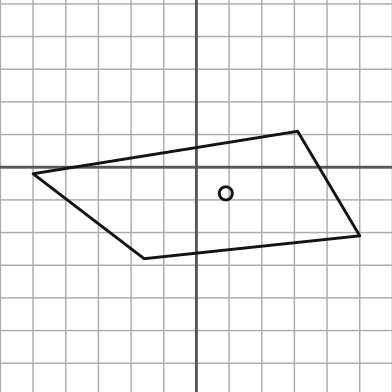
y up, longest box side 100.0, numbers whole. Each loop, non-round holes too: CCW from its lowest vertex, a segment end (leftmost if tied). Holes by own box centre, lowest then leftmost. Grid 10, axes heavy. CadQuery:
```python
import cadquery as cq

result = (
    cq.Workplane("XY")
    .moveTo(-16.0, -28.0)
    .lineTo(50.0, -21.0)
    .lineTo(31.0, 11.0)
    .lineTo(-50.0, -2.0)
    .close()
    .moveTo(9.0, -8.0)
    .circle(2.0)
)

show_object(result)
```